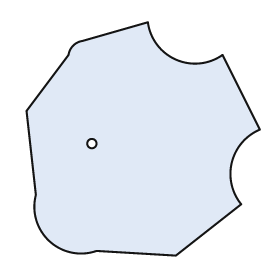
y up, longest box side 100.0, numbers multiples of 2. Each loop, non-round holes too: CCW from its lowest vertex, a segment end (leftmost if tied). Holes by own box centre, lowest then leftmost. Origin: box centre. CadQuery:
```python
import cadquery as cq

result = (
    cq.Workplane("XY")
    .moveTo(14.0, -50.0)
    .lineTo(42.0, -28.0)
    .threePointArc((38.0, -10.0), (50.0, 4.0))
    .lineTo(34.0, 36.0)
    .threePointArc((14.0, 34.0), (2.0, 50.0))
    .lineTo(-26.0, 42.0)
    .threePointArc((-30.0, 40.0), (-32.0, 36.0))
    .lineTo(-50.0, 12.0)
    .lineTo(-46.0, -24.0)
    .threePointArc((-40.0, -44.0), (-20.0, -48.0))
    .close()
    .moveTo(-22.0, -2.0)
    .circle(2.0)
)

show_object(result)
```